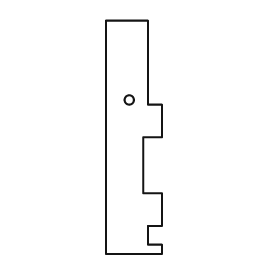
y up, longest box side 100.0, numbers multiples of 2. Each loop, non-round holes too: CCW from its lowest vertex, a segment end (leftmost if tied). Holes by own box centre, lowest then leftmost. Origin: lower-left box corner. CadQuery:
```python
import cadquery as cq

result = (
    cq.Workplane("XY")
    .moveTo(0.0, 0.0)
    .lineTo(24.0, 0.0)
    .lineTo(24.0, 4.0)
    .lineTo(18.0, 4.0)
    .lineTo(18.0, 12.0)
    .lineTo(24.0, 12.0)
    .lineTo(24.0, 26.0)
    .lineTo(16.0, 26.0)
    .lineTo(16.0, 50.0)
    .lineTo(24.0, 50.0)
    .lineTo(24.0, 64.0)
    .lineTo(18.0, 64.0)
    .lineTo(18.0, 100.0)
    .lineTo(0.0, 100.0)
    .close()
    .moveTo(10.0, 66.0)
    .circle(2.0)
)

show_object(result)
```